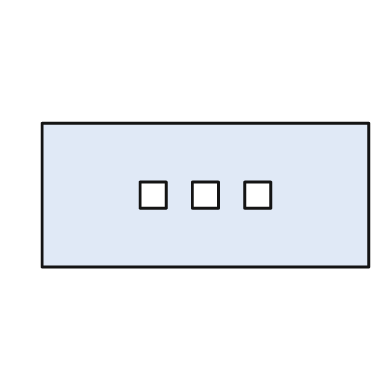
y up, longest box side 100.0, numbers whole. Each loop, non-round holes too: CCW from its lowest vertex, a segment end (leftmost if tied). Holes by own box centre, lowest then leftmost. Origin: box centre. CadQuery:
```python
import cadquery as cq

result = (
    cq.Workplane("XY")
    .moveTo(-50.0, -22.0)
    .lineTo(50.0, -22.0)
    .lineTo(50.0, 22.0)
    .lineTo(-50.0, 22.0)
    .close()
    .moveTo(-20.0, -4.0)
    .lineTo(-12.0, -4.0)
    .lineTo(-12.0, 4.0)
    .lineTo(-20.0, 4.0)
    .close()
    .moveTo(-4.0, -4.0)
    .lineTo(4.0, -4.0)
    .lineTo(4.0, 4.0)
    .lineTo(-4.0, 4.0)
    .close()
    .moveTo(12.0, -4.0)
    .lineTo(20.0, -4.0)
    .lineTo(20.0, 4.0)
    .lineTo(12.0, 4.0)
    .close()
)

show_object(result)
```